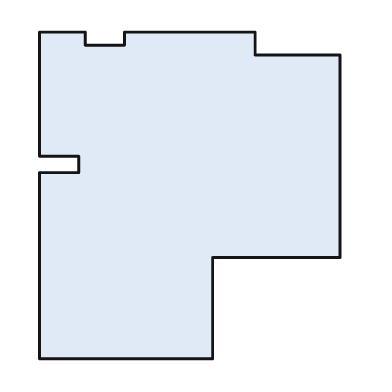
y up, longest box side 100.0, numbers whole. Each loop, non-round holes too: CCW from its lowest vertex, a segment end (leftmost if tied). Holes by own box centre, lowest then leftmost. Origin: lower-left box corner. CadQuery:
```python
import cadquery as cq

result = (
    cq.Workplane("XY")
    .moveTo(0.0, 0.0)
    .lineTo(53.0, 0.0)
    .lineTo(53.0, 31.0)
    .lineTo(92.0, 31.0)
    .lineTo(92.0, 93.0)
    .lineTo(66.0, 93.0)
    .lineTo(66.0, 100.0)
    .lineTo(26.0, 100.0)
    .lineTo(26.0, 96.0)
    .lineTo(14.0, 96.0)
    .lineTo(14.0, 100.0)
    .lineTo(0.0, 100.0)
    .lineTo(0.0, 62.0)
    .lineTo(12.0, 62.0)
    .lineTo(12.0, 57.0)
    .lineTo(0.0, 57.0)
    .close()
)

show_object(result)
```